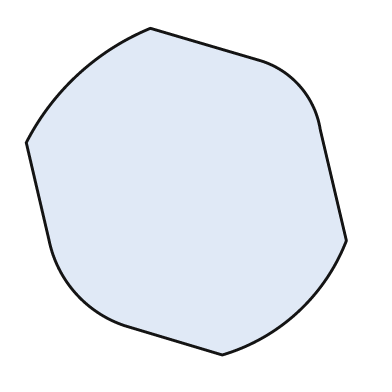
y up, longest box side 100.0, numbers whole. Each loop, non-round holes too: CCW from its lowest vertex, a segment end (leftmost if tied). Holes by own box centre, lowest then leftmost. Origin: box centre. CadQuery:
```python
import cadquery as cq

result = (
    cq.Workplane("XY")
    .moveTo(11.0, -50.0)
    .threePointArc((34.0, -37.0), (49.0, -15.0))
    .lineTo(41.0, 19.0)
    .threePointArc((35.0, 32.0), (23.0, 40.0))
    .lineTo(-11.0, 50.0)
    .threePointArc((-33.0, 36.0), (-49.0, 15.0))
    .lineTo(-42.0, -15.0)
    .threePointArc((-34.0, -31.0), (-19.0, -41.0))
    .close()
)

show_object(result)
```